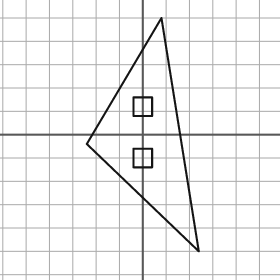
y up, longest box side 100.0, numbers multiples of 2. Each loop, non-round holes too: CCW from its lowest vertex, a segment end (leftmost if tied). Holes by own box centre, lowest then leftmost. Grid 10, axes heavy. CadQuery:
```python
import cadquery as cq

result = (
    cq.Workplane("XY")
    .moveTo(24.0, -50.0)
    .lineTo(8.0, 50.0)
    .lineTo(-24.0, -4.0)
    .close()
    .moveTo(-4.0, -14.0)
    .lineTo(4.0, -14.0)
    .lineTo(4.0, -6.0)
    .lineTo(-4.0, -6.0)
    .close()
    .moveTo(-4.0, 8.0)
    .lineTo(4.0, 8.0)
    .lineTo(4.0, 16.0)
    .lineTo(-4.0, 16.0)
    .close()
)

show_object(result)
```